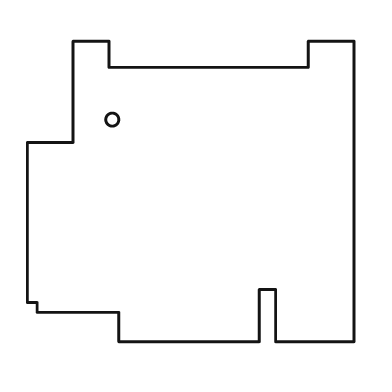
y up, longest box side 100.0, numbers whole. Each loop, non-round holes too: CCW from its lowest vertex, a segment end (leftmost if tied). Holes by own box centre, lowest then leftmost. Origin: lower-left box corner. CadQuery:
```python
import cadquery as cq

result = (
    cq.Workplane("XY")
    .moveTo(28.0, 0.0)
    .lineTo(71.0, 0.0)
    .lineTo(71.0, 16.0)
    .lineTo(76.0, 16.0)
    .lineTo(76.0, 0.0)
    .lineTo(100.0, 0.0)
    .lineTo(100.0, 92.0)
    .lineTo(86.0, 92.0)
    .lineTo(86.0, 84.0)
    .lineTo(25.0, 84.0)
    .lineTo(25.0, 92.0)
    .lineTo(14.0, 92.0)
    .lineTo(14.0, 61.0)
    .lineTo(0.0, 61.0)
    .lineTo(0.0, 12.0)
    .lineTo(3.0, 12.0)
    .lineTo(3.0, 9.0)
    .lineTo(28.0, 9.0)
    .close()
    .moveTo(26.0, 68.0)
    .circle(2.0)
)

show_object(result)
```